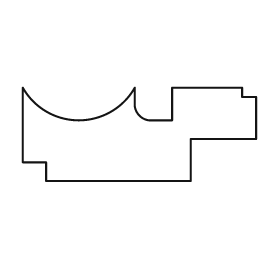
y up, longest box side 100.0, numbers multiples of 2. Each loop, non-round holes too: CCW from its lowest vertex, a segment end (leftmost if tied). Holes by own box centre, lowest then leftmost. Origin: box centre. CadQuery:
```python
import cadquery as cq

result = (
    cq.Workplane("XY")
    .moveTo(-40.0, -20.0)
    .lineTo(22.0, -20.0)
    .lineTo(22.0, -2.0)
    .lineTo(50.0, -2.0)
    .lineTo(50.0, 16.0)
    .lineTo(44.0, 16.0)
    .lineTo(44.0, 20.0)
    .lineTo(14.0, 20.0)
    .lineTo(14.0, 6.0)
    .lineTo(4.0, 6.0)
    .threePointArc((0.0, 8.0), (-2.0, 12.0))
    .lineTo(-2.0, 20.0)
    .threePointArc((-26.0, 6.0), (-50.0, 20.0))
    .lineTo(-50.0, -12.0)
    .lineTo(-40.0, -12.0)
    .close()
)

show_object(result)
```